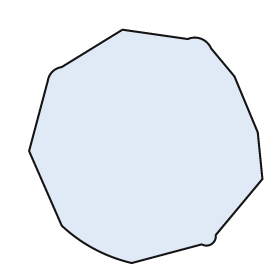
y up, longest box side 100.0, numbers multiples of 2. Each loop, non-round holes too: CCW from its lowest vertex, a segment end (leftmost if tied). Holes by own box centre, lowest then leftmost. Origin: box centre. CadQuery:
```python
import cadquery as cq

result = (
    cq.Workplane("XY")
    .moveTo(-6.0, -50.0)
    .lineTo(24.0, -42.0)
    .threePointArc((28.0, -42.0), (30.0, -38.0))
    .lineTo(50.0, -14.0)
    .lineTo(48.0, 6.0)
    .lineTo(38.0, 30.0)
    .lineTo(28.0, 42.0)
    .threePointArc((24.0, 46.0), (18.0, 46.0))
    .lineTo(-10.0, 50.0)
    .lineTo(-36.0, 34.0)
    .threePointArc((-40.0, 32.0), (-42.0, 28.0))
    .lineTo(-50.0, -2.0)
    .lineTo(-36.0, -34.0)
    .threePointArc((-22.0, -44.0), (-6.0, -50.0))
    .close()
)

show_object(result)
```